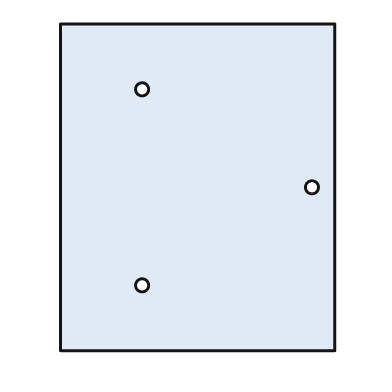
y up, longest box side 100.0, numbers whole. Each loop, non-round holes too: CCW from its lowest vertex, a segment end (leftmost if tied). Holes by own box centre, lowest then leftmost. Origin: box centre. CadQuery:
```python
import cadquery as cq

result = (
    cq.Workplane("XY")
    .moveTo(-42.0, -50.0)
    .lineTo(42.0, -50.0)
    .lineTo(42.0, 50.0)
    .lineTo(-42.0, 50.0)
    .close()
    .moveTo(-17.0, -30.0)
    .circle(2.0)
    .moveTo(35.0, 0.0)
    .circle(2.0)
    .moveTo(-17.0, 30.0)
    .circle(2.0)
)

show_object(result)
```